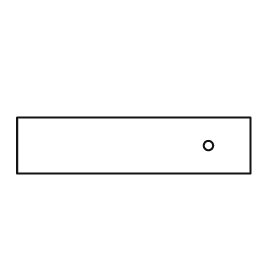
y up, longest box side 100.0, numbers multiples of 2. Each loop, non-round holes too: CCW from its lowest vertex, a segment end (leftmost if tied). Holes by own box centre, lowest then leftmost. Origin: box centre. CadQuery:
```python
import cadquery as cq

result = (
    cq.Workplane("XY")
    .moveTo(-50.0, -12.0)
    .lineTo(50.0, -12.0)
    .lineTo(50.0, 12.0)
    .lineTo(-50.0, 12.0)
    .close()
    .moveTo(32.0, 0.0)
    .circle(2.0)
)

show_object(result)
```